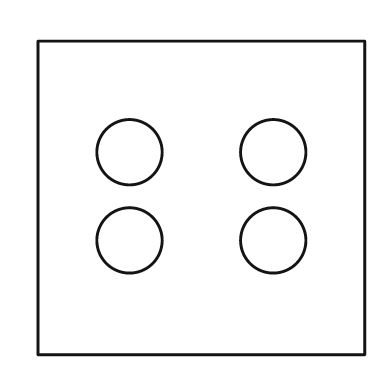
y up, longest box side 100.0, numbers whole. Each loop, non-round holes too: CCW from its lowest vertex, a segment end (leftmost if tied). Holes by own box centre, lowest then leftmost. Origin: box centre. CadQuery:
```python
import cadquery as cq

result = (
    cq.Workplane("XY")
    .moveTo(-50.0, -48.0)
    .lineTo(50.0, -48.0)
    .lineTo(50.0, 48.0)
    .lineTo(-50.0, 48.0)
    .close()
    .moveTo(-22.0, -13.0)
    .circle(10.0)
    .moveTo(22.0, -13.0)
    .circle(10.0)
    .moveTo(-22.0, 14.0)
    .circle(10.0)
    .moveTo(22.0, 14.0)
    .circle(10.0)
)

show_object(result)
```